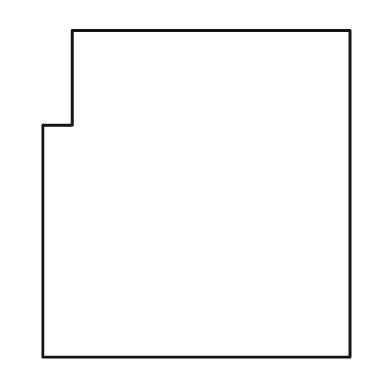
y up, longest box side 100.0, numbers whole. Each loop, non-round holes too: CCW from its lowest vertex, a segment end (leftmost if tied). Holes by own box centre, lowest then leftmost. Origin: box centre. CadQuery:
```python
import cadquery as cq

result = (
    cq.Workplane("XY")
    .moveTo(-47.0, -50.0)
    .lineTo(47.0, -50.0)
    .lineTo(47.0, 50.0)
    .lineTo(-38.0, 50.0)
    .lineTo(-38.0, 21.0)
    .lineTo(-47.0, 21.0)
    .close()
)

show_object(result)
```